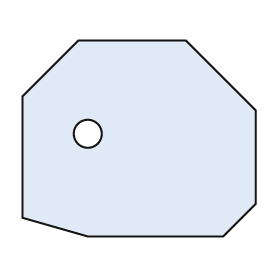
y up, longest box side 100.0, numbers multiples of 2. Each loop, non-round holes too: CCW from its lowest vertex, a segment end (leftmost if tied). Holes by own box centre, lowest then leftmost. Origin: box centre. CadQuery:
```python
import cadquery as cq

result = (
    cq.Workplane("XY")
    .moveTo(-22.0, -42.0)
    .lineTo(36.0, -42.0)
    .lineTo(50.0, -28.0)
    .lineTo(50.0, 12.0)
    .lineTo(20.0, 42.0)
    .lineTo(-26.0, 42.0)
    .lineTo(-50.0, 18.0)
    .lineTo(-50.0, -34.0)
    .close()
    .moveTo(-22.0, 2.0)
    .circle(6.0)
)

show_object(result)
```